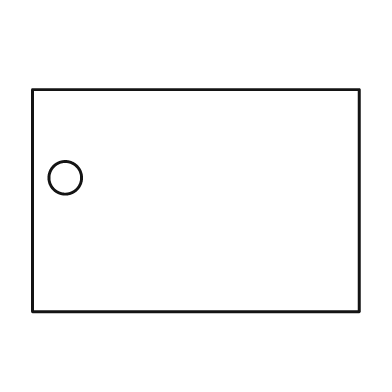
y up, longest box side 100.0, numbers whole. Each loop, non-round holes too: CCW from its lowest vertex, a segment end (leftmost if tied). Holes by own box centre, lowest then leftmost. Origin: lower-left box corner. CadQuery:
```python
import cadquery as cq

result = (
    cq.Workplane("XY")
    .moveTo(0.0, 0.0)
    .lineTo(100.0, 0.0)
    .lineTo(100.0, 68.0)
    .lineTo(0.0, 68.0)
    .close()
    .moveTo(10.0, 41.0)
    .circle(5.0)
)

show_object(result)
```